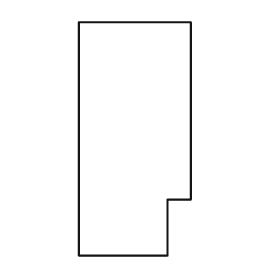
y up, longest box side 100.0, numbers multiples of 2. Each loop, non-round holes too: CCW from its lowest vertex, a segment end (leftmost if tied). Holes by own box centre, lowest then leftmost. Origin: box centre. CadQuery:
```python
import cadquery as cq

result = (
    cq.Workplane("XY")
    .moveTo(-24.0, -50.0)
    .lineTo(14.0, -50.0)
    .lineTo(14.0, -26.0)
    .lineTo(24.0, -26.0)
    .lineTo(24.0, 50.0)
    .lineTo(-24.0, 50.0)
    .close()
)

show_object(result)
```